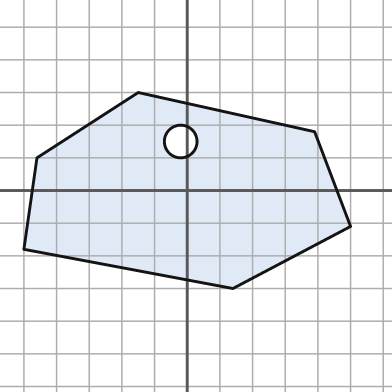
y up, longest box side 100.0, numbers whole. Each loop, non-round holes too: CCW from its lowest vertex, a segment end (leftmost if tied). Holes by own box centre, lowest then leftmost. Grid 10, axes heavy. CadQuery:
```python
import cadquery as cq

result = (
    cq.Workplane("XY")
    .moveTo(14.0, -30.0)
    .lineTo(50.0, -11.0)
    .lineTo(39.0, 18.0)
    .lineTo(-15.0, 30.0)
    .lineTo(-46.0, 10.0)
    .lineTo(-50.0, -18.0)
    .close()
    .moveTo(-2.0, 15.0)
    .circle(5.0)
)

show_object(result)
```